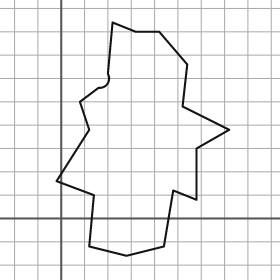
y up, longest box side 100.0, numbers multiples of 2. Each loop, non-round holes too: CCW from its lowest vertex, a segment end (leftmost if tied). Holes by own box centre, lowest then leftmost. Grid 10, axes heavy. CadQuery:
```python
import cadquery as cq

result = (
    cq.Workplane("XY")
    .moveTo(28.0, -16.0)
    .lineTo(44.0, -12.0)
    .lineTo(48.0, 12.0)
    .lineTo(58.0, 8.0)
    .lineTo(58.0, 30.0)
    .lineTo(72.0, 38.0)
    .lineTo(52.0, 48.0)
    .lineTo(54.0, 66.0)
    .lineTo(42.0, 80.0)
    .lineTo(32.0, 80.0)
    .lineTo(22.0, 84.0)
    .lineTo(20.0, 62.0)
    .threePointArc((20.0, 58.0), (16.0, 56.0))
    .lineTo(8.0, 50.0)
    .lineTo(12.0, 38.0)
    .lineTo(-2.0, 16.0)
    .lineTo(14.0, 10.0)
    .lineTo(12.0, -12.0)
    .close()
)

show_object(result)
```